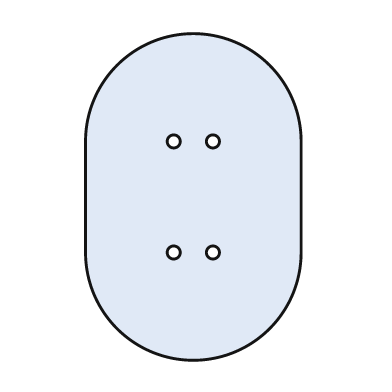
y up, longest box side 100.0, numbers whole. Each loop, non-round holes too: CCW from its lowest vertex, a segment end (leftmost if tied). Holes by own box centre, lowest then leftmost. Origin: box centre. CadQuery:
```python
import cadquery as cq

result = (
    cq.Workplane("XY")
    .moveTo(-33.0, -17.0)
    .threePointArc((0.0, -50.0), (33.0, -17.0))
    .lineTo(33.0, 17.0)
    .threePointArc((0.0, 50.0), (-33.0, 17.0))
    .close()
    .moveTo(-6.0, -17.0)
    .circle(2.0)
    .moveTo(6.0, -17.0)
    .circle(2.0)
    .moveTo(-6.0, 17.0)
    .circle(2.0)
    .moveTo(6.0, 17.0)
    .circle(2.0)
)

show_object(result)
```